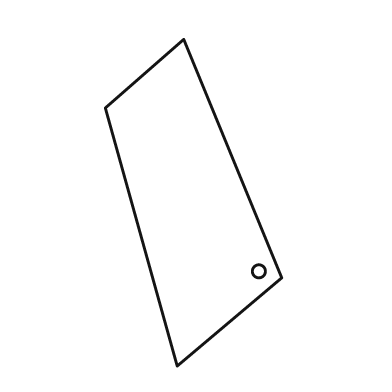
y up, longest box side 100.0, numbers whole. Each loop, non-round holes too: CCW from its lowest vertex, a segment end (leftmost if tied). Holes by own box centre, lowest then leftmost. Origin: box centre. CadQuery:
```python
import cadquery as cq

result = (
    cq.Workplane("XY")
    .moveTo(-5.0, -50.0)
    .lineTo(27.0, -23.0)
    .lineTo(-3.0, 50.0)
    .lineTo(-27.0, 29.0)
    .close()
    .moveTo(20.0, -21.0)
    .circle(2.0)
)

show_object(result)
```